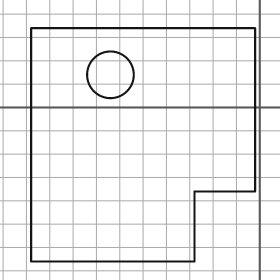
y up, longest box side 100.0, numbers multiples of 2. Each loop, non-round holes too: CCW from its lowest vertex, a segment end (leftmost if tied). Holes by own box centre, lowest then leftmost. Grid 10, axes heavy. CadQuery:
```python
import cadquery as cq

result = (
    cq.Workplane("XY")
    .moveTo(-98.0, -66.0)
    .lineTo(-28.0, -66.0)
    .lineTo(-28.0, -36.0)
    .lineTo(-2.0, -36.0)
    .lineTo(-2.0, 34.0)
    .lineTo(-98.0, 34.0)
    .close()
    .moveTo(-64.0, 14.0)
    .circle(10.0)
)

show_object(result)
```